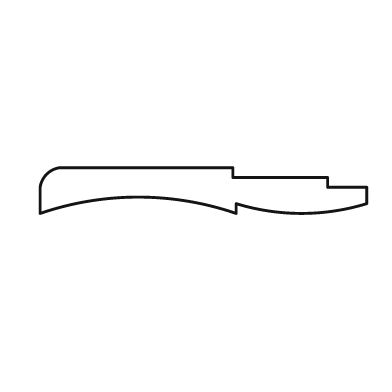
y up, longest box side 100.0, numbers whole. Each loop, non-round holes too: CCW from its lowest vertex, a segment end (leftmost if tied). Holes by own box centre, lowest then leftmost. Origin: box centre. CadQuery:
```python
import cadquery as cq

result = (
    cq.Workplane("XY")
    .moveTo(-50.0, -7.0)
    .threePointArc((-20.0, -2.0), (10.0, -7.0))
    .lineTo(10.0, -4.0)
    .threePointArc((30.0, -7.0), (50.0, -4.0))
    .lineTo(50.0, 1.0)
    .lineTo(38.0, 1.0)
    .lineTo(38.0, 4.0)
    .lineTo(9.0, 4.0)
    .lineTo(9.0, 7.0)
    .lineTo(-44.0, 7.0)
    .threePointArc((-48.0, 5.0), (-50.0, 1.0))
    .close()
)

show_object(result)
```